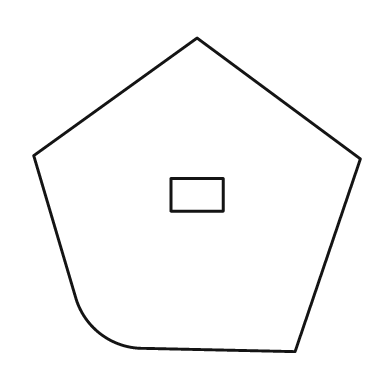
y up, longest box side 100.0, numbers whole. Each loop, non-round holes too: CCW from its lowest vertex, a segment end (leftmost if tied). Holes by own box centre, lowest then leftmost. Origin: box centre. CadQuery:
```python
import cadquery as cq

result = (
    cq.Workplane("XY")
    .moveTo(30.0, -48.0)
    .lineTo(50.0, 11.0)
    .lineTo(0.0, 48.0)
    .lineTo(-50.0, 12.0)
    .lineTo(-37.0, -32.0)
    .threePointArc((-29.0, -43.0), (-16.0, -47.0))
    .close()
    .moveTo(-8.0, -5.0)
    .lineTo(8.0, -5.0)
    .lineTo(8.0, 5.0)
    .lineTo(-8.0, 5.0)
    .close()
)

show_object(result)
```